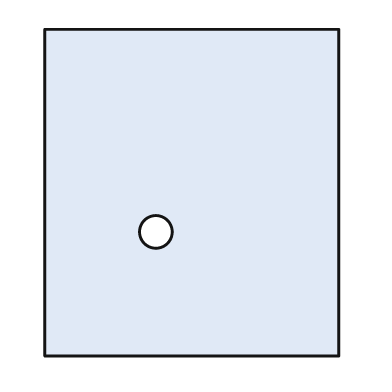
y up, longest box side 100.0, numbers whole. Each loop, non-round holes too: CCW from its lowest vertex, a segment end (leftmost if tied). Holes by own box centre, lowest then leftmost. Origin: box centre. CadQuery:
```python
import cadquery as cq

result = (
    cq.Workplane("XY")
    .moveTo(-45.0, -50.0)
    .lineTo(45.0, -50.0)
    .lineTo(45.0, 50.0)
    .lineTo(-45.0, 50.0)
    .close()
    .moveTo(-11.0, -12.0)
    .circle(5.0)
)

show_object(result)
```